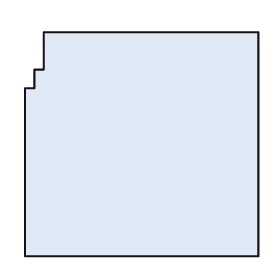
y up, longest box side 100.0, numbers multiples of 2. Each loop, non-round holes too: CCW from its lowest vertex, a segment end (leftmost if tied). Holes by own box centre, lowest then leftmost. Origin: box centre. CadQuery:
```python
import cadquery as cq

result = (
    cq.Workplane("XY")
    .moveTo(-50.0, -48.0)
    .lineTo(50.0, -48.0)
    .lineTo(50.0, 48.0)
    .lineTo(-42.0, 48.0)
    .lineTo(-42.0, 32.0)
    .lineTo(-46.0, 32.0)
    .lineTo(-46.0, 24.0)
    .lineTo(-50.0, 24.0)
    .close()
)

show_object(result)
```